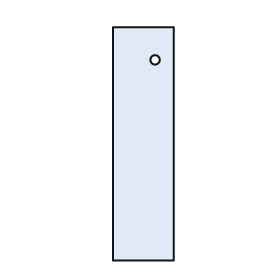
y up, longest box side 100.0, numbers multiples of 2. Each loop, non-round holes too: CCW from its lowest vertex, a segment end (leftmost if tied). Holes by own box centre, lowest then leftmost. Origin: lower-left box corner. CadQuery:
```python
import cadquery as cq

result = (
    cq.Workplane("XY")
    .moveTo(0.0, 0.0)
    .lineTo(26.0, 0.0)
    .lineTo(26.0, 100.0)
    .lineTo(0.0, 100.0)
    .close()
    .moveTo(18.0, 86.0)
    .circle(2.0)
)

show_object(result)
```